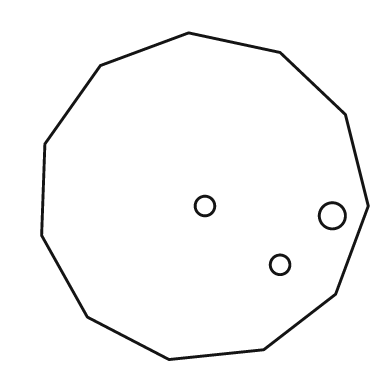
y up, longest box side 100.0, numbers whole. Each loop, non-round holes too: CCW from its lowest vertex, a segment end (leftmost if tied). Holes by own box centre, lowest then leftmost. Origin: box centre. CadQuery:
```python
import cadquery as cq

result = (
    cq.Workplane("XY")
    .moveTo(-11.0, -50.0)
    .lineTo(18.0, -47.0)
    .lineTo(40.0, -30.0)
    .lineTo(50.0, -3.0)
    .lineTo(43.0, 25.0)
    .lineTo(23.0, 44.0)
    .lineTo(-5.0, 50.0)
    .lineTo(-32.0, 40.0)
    .lineTo(-49.0, 16.0)
    .lineTo(-50.0, -12.0)
    .lineTo(-36.0, -37.0)
    .close()
    .moveTo(23.0, -21.0)
    .circle(3.0)
    .moveTo(39.0, -6.0)
    .circle(4.0)
    .moveTo(0.0, -3.0)
    .circle(3.0)
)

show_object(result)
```